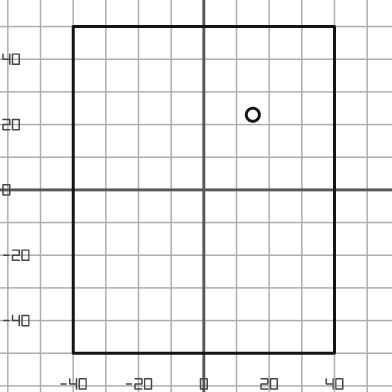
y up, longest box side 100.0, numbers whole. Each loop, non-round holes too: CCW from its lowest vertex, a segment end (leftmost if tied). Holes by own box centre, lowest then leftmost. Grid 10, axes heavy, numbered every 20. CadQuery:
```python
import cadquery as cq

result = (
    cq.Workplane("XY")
    .moveTo(-40.0, -50.0)
    .lineTo(40.0, -50.0)
    .lineTo(40.0, 50.0)
    .lineTo(-40.0, 50.0)
    .close()
    .moveTo(15.0, 23.0)
    .circle(2.0)
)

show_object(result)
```